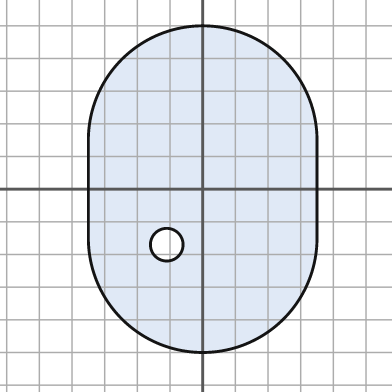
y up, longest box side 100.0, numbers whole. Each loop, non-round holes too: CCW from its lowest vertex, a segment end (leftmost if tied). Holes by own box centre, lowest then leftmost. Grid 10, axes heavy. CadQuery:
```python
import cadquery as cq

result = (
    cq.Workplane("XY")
    .moveTo(-35.0, -15.0)
    .threePointArc((0.0, -50.0), (35.0, -15.0))
    .lineTo(35.0, 15.0)
    .threePointArc((0.0, 50.0), (-35.0, 15.0))
    .close()
    .moveTo(-11.0, -17.0)
    .circle(5.0)
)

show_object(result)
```